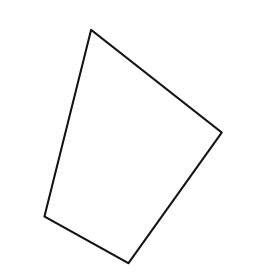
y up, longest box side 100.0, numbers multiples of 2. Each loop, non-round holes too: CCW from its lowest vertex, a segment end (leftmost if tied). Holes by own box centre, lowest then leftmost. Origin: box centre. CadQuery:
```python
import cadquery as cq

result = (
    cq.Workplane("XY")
    .moveTo(-2.0, -50.0)
    .lineTo(38.0, 6.0)
    .lineTo(-18.0, 50.0)
    .lineTo(-38.0, -30.0)
    .close()
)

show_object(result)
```